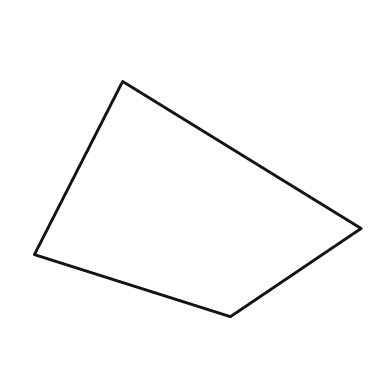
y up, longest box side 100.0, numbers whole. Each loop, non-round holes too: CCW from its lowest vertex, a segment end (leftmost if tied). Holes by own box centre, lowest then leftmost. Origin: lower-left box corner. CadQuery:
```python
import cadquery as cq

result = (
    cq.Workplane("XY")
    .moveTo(60.0, 0.0)
    .lineTo(100.0, 27.0)
    .lineTo(27.0, 72.0)
    .lineTo(0.0, 19.0)
    .close()
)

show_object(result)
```